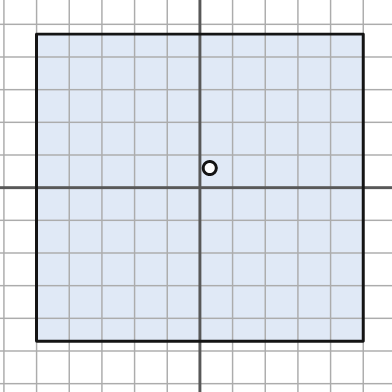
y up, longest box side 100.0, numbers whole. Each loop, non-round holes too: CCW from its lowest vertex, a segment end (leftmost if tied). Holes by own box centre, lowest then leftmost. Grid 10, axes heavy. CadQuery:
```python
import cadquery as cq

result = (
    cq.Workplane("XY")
    .moveTo(-50.0, -47.0)
    .lineTo(50.0, -47.0)
    .lineTo(50.0, 47.0)
    .lineTo(-50.0, 47.0)
    .close()
    .moveTo(3.0, 6.0)
    .circle(2.0)
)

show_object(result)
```